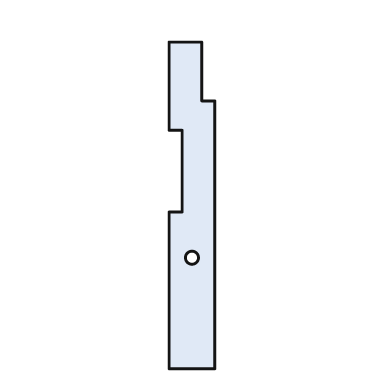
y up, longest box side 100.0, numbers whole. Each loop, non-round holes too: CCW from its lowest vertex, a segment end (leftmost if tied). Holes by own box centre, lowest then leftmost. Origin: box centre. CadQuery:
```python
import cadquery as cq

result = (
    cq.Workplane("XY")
    .moveTo(-7.0, -50.0)
    .lineTo(7.0, -50.0)
    .lineTo(7.0, 32.0)
    .lineTo(3.0, 32.0)
    .lineTo(3.0, 50.0)
    .lineTo(-7.0, 50.0)
    .lineTo(-7.0, 23.0)
    .lineTo(-3.0, 23.0)
    .lineTo(-3.0, -2.0)
    .lineTo(-7.0, -2.0)
    .close()
    .moveTo(0.0, -16.0)
    .circle(2.0)
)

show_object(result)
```